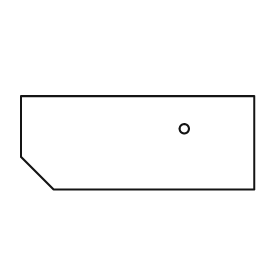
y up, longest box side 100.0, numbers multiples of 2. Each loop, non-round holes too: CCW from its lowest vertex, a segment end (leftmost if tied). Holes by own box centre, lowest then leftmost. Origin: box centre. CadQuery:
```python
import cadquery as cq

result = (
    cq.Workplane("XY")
    .moveTo(-36.0, -20.0)
    .lineTo(50.0, -20.0)
    .lineTo(50.0, 20.0)
    .lineTo(-50.0, 20.0)
    .lineTo(-50.0, -6.0)
    .close()
    .moveTo(20.0, 6.0)
    .circle(2.0)
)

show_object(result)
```